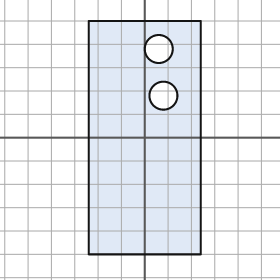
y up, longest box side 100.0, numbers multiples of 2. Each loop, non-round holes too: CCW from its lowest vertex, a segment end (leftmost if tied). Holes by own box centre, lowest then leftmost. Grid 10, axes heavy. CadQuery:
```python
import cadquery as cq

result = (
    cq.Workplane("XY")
    .moveTo(-24.0, -50.0)
    .lineTo(24.0, -50.0)
    .lineTo(24.0, 50.0)
    .lineTo(-24.0, 50.0)
    .close()
    .moveTo(8.0, 18.0)
    .circle(6.0)
    .moveTo(6.0, 38.0)
    .circle(6.0)
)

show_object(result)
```